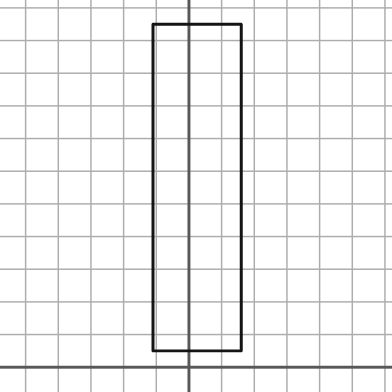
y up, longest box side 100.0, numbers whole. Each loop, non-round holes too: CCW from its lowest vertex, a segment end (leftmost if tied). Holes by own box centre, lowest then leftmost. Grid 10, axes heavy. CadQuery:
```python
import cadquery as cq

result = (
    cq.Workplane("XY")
    .moveTo(-11.0, 5.0)
    .lineTo(16.0, 5.0)
    .lineTo(16.0, 105.0)
    .lineTo(-11.0, 105.0)
    .close()
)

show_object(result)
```